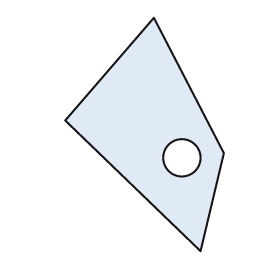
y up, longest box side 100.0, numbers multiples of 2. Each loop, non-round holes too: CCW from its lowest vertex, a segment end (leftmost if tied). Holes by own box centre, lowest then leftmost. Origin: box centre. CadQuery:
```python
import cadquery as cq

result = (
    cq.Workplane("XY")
    .moveTo(24.0, -50.0)
    .lineTo(34.0, -8.0)
    .lineTo(4.0, 50.0)
    .lineTo(-34.0, 6.0)
    .close()
    .moveTo(16.0, -10.0)
    .circle(8.0)
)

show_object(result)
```